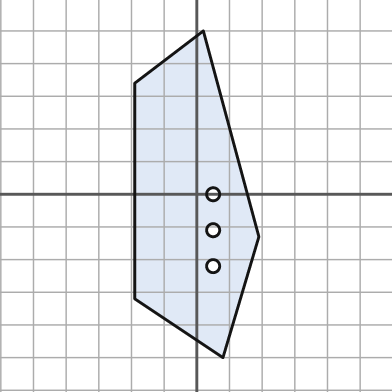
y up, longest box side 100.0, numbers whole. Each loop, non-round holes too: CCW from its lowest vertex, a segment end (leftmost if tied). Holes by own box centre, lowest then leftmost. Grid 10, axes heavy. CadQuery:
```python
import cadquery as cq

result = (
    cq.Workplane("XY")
    .moveTo(8.0, -50.0)
    .lineTo(19.0, -13.0)
    .lineTo(2.0, 50.0)
    .lineTo(-19.0, 34.0)
    .lineTo(-19.0, -32.0)
    .close()
    .moveTo(5.0, -22.0)
    .circle(2.0)
    .moveTo(5.0, -11.0)
    .circle(2.0)
    .moveTo(5.0, 0.0)
    .circle(2.0)
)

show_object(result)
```